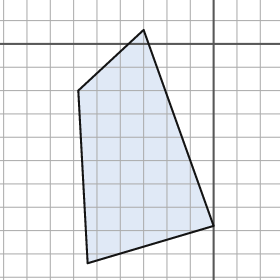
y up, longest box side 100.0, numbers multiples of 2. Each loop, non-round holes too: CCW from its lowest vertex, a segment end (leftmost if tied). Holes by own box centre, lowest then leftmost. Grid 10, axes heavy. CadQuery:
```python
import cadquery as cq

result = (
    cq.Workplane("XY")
    .moveTo(-54.0, -94.0)
    .lineTo(0.0, -78.0)
    .lineTo(-30.0, 6.0)
    .lineTo(-58.0, -20.0)
    .close()
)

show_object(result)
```